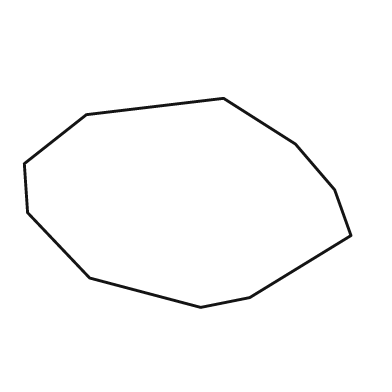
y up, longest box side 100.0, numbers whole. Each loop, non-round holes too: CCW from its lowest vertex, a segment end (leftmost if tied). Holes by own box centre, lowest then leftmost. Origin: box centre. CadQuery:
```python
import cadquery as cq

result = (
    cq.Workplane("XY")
    .moveTo(4.0, -32.0)
    .lineTo(19.0, -29.0)
    .lineTo(50.0, -10.0)
    .lineTo(45.0, 4.0)
    .lineTo(33.0, 18.0)
    .lineTo(11.0, 32.0)
    .lineTo(-31.0, 27.0)
    .lineTo(-50.0, 12.0)
    .lineTo(-49.0, -3.0)
    .lineTo(-30.0, -23.0)
    .close()
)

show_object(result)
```